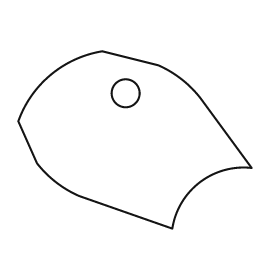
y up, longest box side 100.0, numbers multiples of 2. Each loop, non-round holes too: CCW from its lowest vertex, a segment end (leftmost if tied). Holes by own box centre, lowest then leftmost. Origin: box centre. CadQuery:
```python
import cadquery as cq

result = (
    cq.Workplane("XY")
    .moveTo(16.0, -38.0)
    .threePointArc((28.0, -18.0), (50.0, -12.0))
    .lineTo(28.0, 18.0)
    .threePointArc((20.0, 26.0), (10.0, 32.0))
    .lineTo(-14.0, 38.0)
    .threePointArc((-36.0, 28.0), (-50.0, 8.0))
    .lineTo(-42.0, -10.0)
    .threePointArc((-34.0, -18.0), (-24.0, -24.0))
    .close()
    .moveTo(-4.0, 20.0)
    .circle(6.0)
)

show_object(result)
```